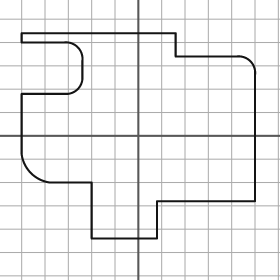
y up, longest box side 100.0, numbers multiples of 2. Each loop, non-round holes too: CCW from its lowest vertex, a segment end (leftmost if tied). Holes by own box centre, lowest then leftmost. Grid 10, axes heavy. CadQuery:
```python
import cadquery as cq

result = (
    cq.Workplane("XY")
    .moveTo(-20.0, -44.0)
    .lineTo(8.0, -44.0)
    .lineTo(8.0, -28.0)
    .lineTo(50.0, -28.0)
    .lineTo(50.0, 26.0)
    .threePointArc((48.0, 32.0), (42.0, 34.0))
    .lineTo(16.0, 34.0)
    .lineTo(16.0, 44.0)
    .lineTo(-50.0, 44.0)
    .lineTo(-50.0, 40.0)
    .lineTo(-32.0, 40.0)
    .threePointArc((-26.0, 38.0), (-24.0, 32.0))
    .lineTo(-24.0, 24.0)
    .threePointArc((-26.0, 20.0), (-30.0, 18.0))
    .lineTo(-50.0, 18.0)
    .lineTo(-50.0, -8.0)
    .threePointArc((-46.0, -16.0), (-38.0, -20.0))
    .lineTo(-20.0, -20.0)
    .close()
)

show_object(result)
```